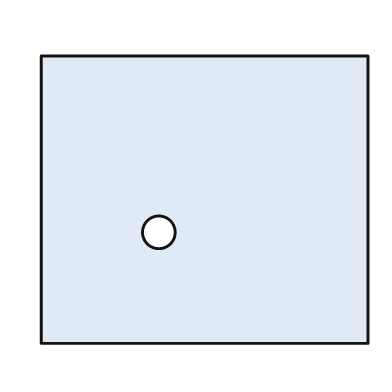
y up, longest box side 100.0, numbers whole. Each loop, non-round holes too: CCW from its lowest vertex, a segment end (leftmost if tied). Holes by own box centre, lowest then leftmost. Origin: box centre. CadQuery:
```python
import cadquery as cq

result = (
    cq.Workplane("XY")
    .moveTo(-50.0, -44.0)
    .lineTo(50.0, -44.0)
    .lineTo(50.0, 44.0)
    .lineTo(-50.0, 44.0)
    .close()
    .moveTo(-14.0, -10.0)
    .circle(5.0)
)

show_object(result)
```